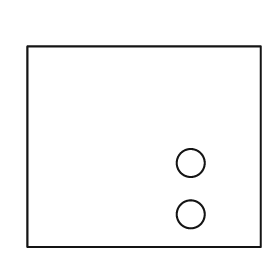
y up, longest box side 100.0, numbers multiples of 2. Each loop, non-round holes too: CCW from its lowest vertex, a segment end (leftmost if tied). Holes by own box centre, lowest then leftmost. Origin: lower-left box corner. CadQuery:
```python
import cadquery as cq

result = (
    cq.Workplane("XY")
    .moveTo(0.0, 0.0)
    .lineTo(100.0, 0.0)
    .lineTo(100.0, 86.0)
    .lineTo(0.0, 86.0)
    .close()
    .moveTo(70.0, 14.0)
    .circle(6.0)
    .moveTo(70.0, 36.0)
    .circle(6.0)
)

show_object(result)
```